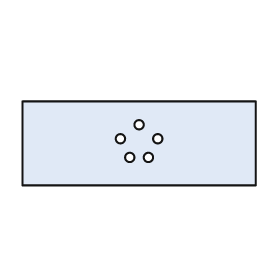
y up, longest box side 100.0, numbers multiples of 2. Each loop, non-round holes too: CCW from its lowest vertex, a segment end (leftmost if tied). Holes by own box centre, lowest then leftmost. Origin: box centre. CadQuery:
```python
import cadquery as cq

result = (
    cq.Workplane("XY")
    .moveTo(-50.0, -18.0)
    .lineTo(50.0, -18.0)
    .lineTo(50.0, 18.0)
    .lineTo(-50.0, 18.0)
    .close()
    .moveTo(-4.0, -6.0)
    .circle(2.0)
    .moveTo(4.0, -6.0)
    .circle(2.0)
    .moveTo(-8.0, 2.0)
    .circle(2.0)
    .moveTo(8.0, 2.0)
    .circle(2.0)
    .moveTo(0.0, 8.0)
    .circle(2.0)
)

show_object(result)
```